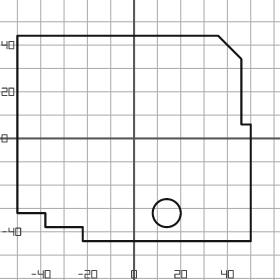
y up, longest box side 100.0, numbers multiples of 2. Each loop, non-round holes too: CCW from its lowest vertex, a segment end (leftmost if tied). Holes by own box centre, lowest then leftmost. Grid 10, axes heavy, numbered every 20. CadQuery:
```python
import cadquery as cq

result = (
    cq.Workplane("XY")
    .moveTo(-22.0, -44.0)
    .lineTo(50.0, -44.0)
    .lineTo(50.0, 6.0)
    .lineTo(46.0, 6.0)
    .lineTo(46.0, 34.0)
    .lineTo(36.0, 44.0)
    .lineTo(-50.0, 44.0)
    .lineTo(-50.0, -32.0)
    .lineTo(-38.0, -32.0)
    .lineTo(-38.0, -38.0)
    .lineTo(-22.0, -38.0)
    .close()
    .moveTo(14.0, -32.0)
    .circle(6.0)
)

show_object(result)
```